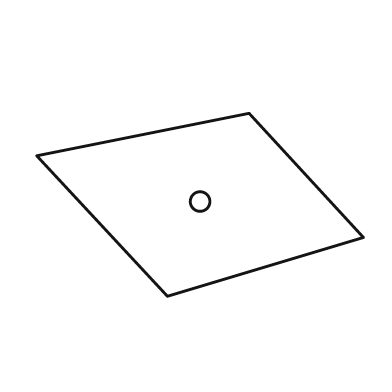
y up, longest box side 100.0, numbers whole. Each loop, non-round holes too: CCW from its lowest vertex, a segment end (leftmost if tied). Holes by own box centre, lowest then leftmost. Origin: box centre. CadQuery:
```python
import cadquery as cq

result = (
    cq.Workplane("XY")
    .moveTo(-10.0, -28.0)
    .lineTo(50.0, -10.0)
    .lineTo(15.0, 28.0)
    .lineTo(-50.0, 15.0)
    .close()
    .moveTo(0.0, 1.0)
    .circle(3.0)
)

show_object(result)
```